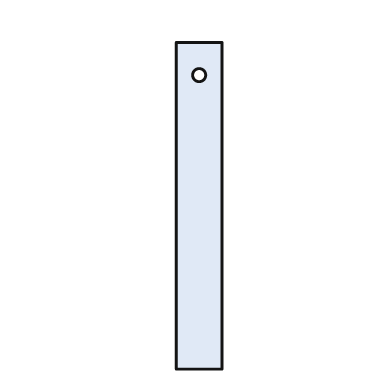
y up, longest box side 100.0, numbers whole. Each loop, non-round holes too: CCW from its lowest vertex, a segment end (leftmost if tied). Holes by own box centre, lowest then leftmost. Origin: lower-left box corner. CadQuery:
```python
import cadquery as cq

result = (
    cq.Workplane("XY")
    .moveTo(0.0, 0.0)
    .lineTo(14.0, 0.0)
    .lineTo(14.0, 100.0)
    .lineTo(0.0, 100.0)
    .close()
    .moveTo(7.0, 90.0)
    .circle(2.0)
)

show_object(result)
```